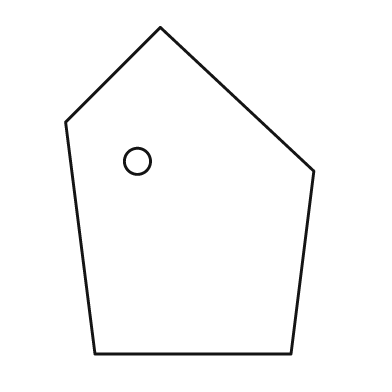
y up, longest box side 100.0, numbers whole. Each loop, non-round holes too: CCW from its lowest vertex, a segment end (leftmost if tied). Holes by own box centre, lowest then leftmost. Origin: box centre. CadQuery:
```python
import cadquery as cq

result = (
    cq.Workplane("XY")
    .moveTo(-29.0, -50.0)
    .lineTo(31.0, -50.0)
    .lineTo(38.0, 6.0)
    .lineTo(-9.0, 50.0)
    .lineTo(-38.0, 21.0)
    .close()
    .moveTo(-16.0, 9.0)
    .circle(4.0)
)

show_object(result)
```